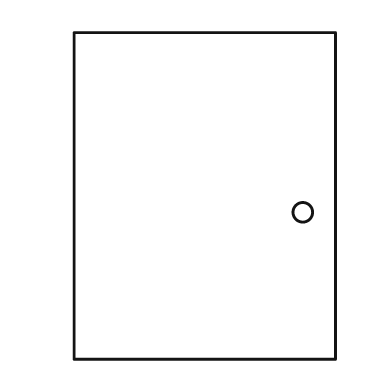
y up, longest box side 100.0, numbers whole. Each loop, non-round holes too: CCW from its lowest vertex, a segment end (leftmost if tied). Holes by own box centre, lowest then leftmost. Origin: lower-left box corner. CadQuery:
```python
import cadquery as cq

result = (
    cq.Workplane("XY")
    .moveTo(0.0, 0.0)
    .lineTo(80.0, 0.0)
    .lineTo(80.0, 100.0)
    .lineTo(0.0, 100.0)
    .close()
    .moveTo(70.0, 45.0)
    .circle(3.0)
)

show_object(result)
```